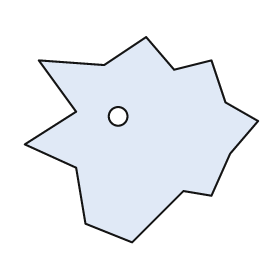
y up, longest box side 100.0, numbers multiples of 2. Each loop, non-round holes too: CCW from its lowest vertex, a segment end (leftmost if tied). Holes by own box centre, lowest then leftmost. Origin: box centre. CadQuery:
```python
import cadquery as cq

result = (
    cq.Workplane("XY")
    .moveTo(-4.0, -44.0)
    .lineTo(18.0, -22.0)
    .lineTo(30.0, -24.0)
    .lineTo(38.0, -6.0)
    .lineTo(50.0, 8.0)
    .lineTo(36.0, 16.0)
    .lineTo(30.0, 34.0)
    .lineTo(14.0, 30.0)
    .lineTo(2.0, 44.0)
    .lineTo(-16.0, 32.0)
    .lineTo(-44.0, 34.0)
    .lineTo(-28.0, 12.0)
    .lineTo(-50.0, -2.0)
    .lineTo(-28.0, -12.0)
    .lineTo(-24.0, -36.0)
    .close()
    .moveTo(-10.0, 10.0)
    .circle(4.0)
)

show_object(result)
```